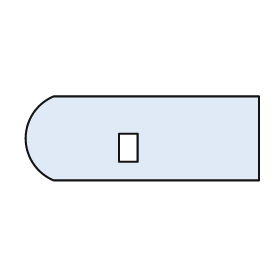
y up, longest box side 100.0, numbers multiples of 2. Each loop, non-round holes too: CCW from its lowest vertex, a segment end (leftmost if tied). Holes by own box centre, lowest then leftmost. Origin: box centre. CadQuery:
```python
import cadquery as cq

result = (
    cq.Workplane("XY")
    .moveTo(-38.0, -18.0)
    .lineTo(50.0, -18.0)
    .lineTo(50.0, 18.0)
    .lineTo(-38.0, 18.0)
    .threePointArc((-50.0, 0.0), (-38.0, -18.0))
    .close()
    .moveTo(-10.0, -10.0)
    .lineTo(-2.0, -10.0)
    .lineTo(-2.0, 2.0)
    .lineTo(-10.0, 2.0)
    .close()
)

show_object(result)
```